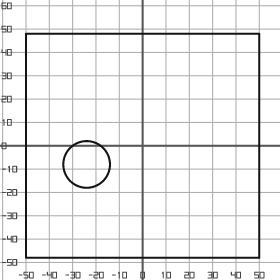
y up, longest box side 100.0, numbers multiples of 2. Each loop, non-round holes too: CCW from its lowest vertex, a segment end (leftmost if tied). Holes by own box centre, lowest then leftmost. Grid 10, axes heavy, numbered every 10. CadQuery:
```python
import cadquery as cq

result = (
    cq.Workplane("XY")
    .moveTo(-50.0, -48.0)
    .lineTo(50.0, -48.0)
    .lineTo(50.0, 48.0)
    .lineTo(-50.0, 48.0)
    .close()
    .moveTo(-24.0, -8.0)
    .circle(10.0)
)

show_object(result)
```